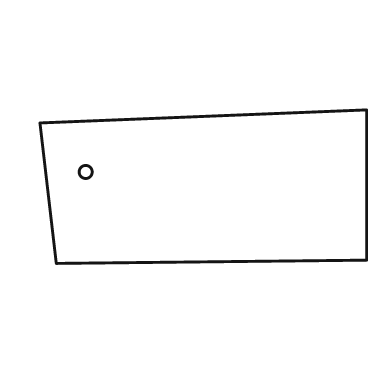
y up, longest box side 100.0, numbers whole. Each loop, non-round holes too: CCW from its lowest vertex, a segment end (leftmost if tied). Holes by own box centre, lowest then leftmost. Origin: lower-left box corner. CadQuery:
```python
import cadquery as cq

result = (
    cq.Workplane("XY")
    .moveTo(5.0, 0.0)
    .lineTo(100.0, 1.0)
    .lineTo(100.0, 47.0)
    .lineTo(0.0, 43.0)
    .close()
    .moveTo(14.0, 28.0)
    .circle(2.0)
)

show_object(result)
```